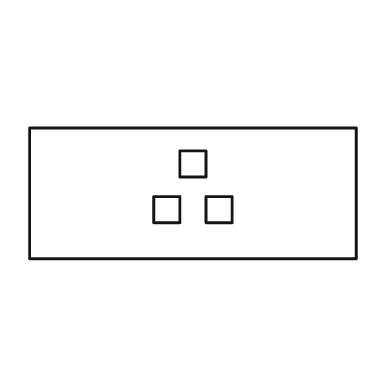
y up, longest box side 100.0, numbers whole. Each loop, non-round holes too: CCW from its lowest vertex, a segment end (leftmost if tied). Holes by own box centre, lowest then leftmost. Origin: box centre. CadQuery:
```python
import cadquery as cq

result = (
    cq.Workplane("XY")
    .moveTo(-50.0, -20.0)
    .lineTo(50.0, -20.0)
    .lineTo(50.0, 20.0)
    .lineTo(-50.0, 20.0)
    .close()
    .moveTo(-12.0, -9.0)
    .lineTo(-4.0, -9.0)
    .lineTo(-4.0, -1.0)
    .lineTo(-12.0, -1.0)
    .close()
    .moveTo(4.0, -9.0)
    .lineTo(12.0, -9.0)
    .lineTo(12.0, -1.0)
    .lineTo(4.0, -1.0)
    .close()
    .moveTo(-4.0, 5.0)
    .lineTo(4.0, 5.0)
    .lineTo(4.0, 13.0)
    .lineTo(-4.0, 13.0)
    .close()
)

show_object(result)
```